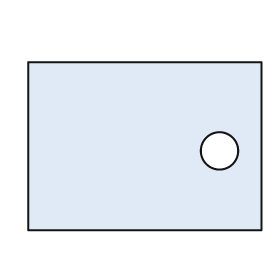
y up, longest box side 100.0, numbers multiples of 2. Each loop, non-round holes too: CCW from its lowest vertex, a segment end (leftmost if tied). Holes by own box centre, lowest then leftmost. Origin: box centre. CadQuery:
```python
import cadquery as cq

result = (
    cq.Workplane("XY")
    .moveTo(-50.0, -36.0)
    .lineTo(50.0, -36.0)
    .lineTo(50.0, 36.0)
    .lineTo(-50.0, 36.0)
    .close()
    .moveTo(32.0, -2.0)
    .circle(8.0)
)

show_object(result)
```